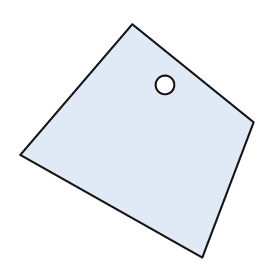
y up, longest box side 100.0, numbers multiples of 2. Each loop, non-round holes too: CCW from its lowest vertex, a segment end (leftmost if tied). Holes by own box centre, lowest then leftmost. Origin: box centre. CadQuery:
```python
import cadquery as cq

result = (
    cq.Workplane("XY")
    .moveTo(28.0, -50.0)
    .lineTo(50.0, 8.0)
    .lineTo(-2.0, 50.0)
    .lineTo(-50.0, -6.0)
    .close()
    .moveTo(12.0, 24.0)
    .circle(4.0)
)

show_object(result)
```